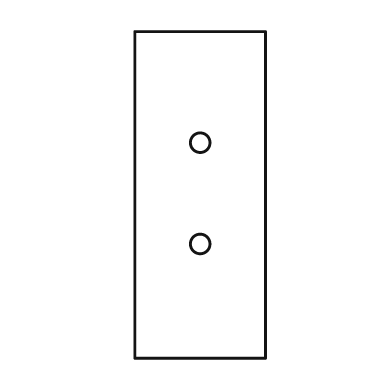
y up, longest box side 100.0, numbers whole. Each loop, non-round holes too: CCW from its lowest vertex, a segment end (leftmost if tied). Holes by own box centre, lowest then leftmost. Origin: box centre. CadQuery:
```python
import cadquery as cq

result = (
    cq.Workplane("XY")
    .moveTo(-20.0, -50.0)
    .lineTo(20.0, -50.0)
    .lineTo(20.0, 50.0)
    .lineTo(-20.0, 50.0)
    .close()
    .moveTo(0.0, -15.0)
    .circle(3.0)
    .moveTo(0.0, 16.0)
    .circle(3.0)
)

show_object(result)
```